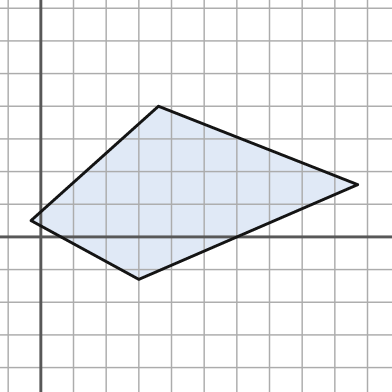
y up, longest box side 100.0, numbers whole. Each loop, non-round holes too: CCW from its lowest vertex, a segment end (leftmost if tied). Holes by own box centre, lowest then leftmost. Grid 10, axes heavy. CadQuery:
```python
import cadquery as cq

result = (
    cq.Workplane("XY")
    .moveTo(30.0, -13.0)
    .lineTo(97.0, 16.0)
    .lineTo(36.0, 40.0)
    .lineTo(-3.0, 5.0)
    .close()
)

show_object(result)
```